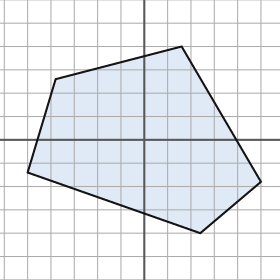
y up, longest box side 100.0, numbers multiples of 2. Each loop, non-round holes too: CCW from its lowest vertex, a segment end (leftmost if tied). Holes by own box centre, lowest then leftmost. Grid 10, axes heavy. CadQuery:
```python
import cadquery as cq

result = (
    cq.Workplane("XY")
    .moveTo(24.0, -40.0)
    .lineTo(50.0, -18.0)
    .lineTo(16.0, 40.0)
    .lineTo(-38.0, 26.0)
    .lineTo(-50.0, -14.0)
    .close()
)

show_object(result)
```